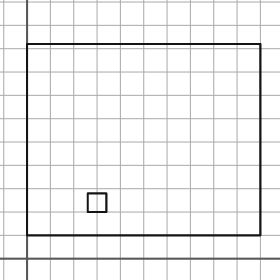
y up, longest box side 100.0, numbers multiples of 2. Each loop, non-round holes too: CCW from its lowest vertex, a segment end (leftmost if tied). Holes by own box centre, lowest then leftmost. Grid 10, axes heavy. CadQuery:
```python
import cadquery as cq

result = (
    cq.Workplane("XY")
    .moveTo(0.0, 10.0)
    .lineTo(100.0, 10.0)
    .lineTo(100.0, 92.0)
    .lineTo(0.0, 92.0)
    .close()
    .moveTo(26.0, 20.0)
    .lineTo(34.0, 20.0)
    .lineTo(34.0, 28.0)
    .lineTo(26.0, 28.0)
    .close()
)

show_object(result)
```